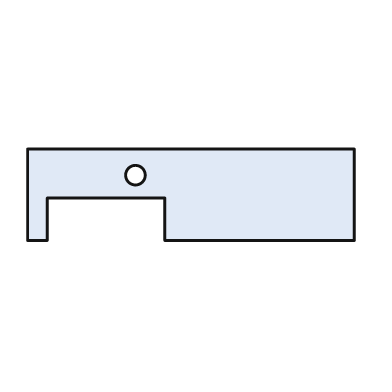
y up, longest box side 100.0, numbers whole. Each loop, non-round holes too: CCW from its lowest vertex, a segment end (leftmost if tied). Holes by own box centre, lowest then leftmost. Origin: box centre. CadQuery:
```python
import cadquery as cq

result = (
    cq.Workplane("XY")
    .moveTo(-50.0, -14.0)
    .lineTo(-44.0, -14.0)
    .lineTo(-44.0, -1.0)
    .lineTo(-8.0, -1.0)
    .lineTo(-8.0, -14.0)
    .lineTo(50.0, -14.0)
    .lineTo(50.0, 14.0)
    .lineTo(-50.0, 14.0)
    .close()
    .moveTo(-17.0, 6.0)
    .circle(3.0)
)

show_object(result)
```